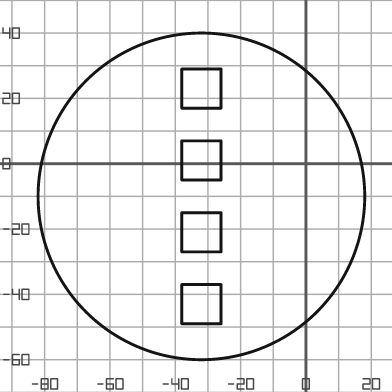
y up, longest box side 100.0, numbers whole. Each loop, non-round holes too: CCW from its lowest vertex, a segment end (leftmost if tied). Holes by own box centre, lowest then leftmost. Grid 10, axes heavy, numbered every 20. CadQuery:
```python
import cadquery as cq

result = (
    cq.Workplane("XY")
    .moveTo(-32.0, -10.0)
    .circle(50.0)
    .moveTo(-38.0, -49.0)
    .lineTo(-26.0, -49.0)
    .lineTo(-26.0, -37.0)
    .lineTo(-38.0, -37.0)
    .close()
    .moveTo(-38.0, -27.0)
    .lineTo(-26.0, -27.0)
    .lineTo(-26.0, -15.0)
    .lineTo(-38.0, -15.0)
    .close()
    .moveTo(-38.0, -5.0)
    .lineTo(-26.0, -5.0)
    .lineTo(-26.0, 7.0)
    .lineTo(-38.0, 7.0)
    .close()
    .moveTo(-38.0, 17.0)
    .lineTo(-26.0, 17.0)
    .lineTo(-26.0, 29.0)
    .lineTo(-38.0, 29.0)
    .close()
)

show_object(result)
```